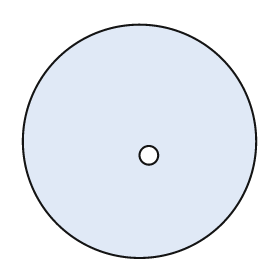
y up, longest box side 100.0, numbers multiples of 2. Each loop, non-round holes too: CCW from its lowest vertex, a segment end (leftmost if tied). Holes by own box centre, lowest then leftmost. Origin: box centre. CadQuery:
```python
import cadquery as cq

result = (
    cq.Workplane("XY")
    .moveTo(0.0, 0.0)
    .circle(50.0)
    .moveTo(4.0, -6.0)
    .circle(4.0)
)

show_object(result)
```